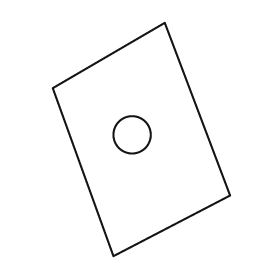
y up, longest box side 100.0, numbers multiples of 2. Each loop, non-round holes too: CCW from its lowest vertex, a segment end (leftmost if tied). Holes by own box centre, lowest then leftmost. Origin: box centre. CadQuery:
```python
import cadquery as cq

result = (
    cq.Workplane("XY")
    .moveTo(-12.0, -50.0)
    .lineTo(38.0, -24.0)
    .lineTo(10.0, 50.0)
    .lineTo(-38.0, 22.0)
    .close()
    .moveTo(-4.0, 2.0)
    .circle(8.0)
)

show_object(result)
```